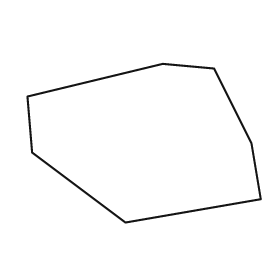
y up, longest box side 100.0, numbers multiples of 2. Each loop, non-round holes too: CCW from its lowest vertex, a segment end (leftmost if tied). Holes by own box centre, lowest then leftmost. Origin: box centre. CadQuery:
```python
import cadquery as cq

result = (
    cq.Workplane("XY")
    .moveTo(-8.0, -34.0)
    .lineTo(50.0, -24.0)
    .lineTo(46.0, 0.0)
    .lineTo(30.0, 32.0)
    .lineTo(8.0, 34.0)
    .lineTo(-50.0, 20.0)
    .lineTo(-48.0, -4.0)
    .close()
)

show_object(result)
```